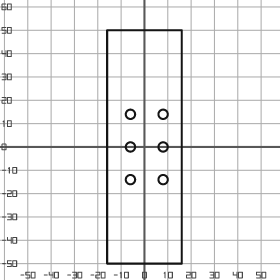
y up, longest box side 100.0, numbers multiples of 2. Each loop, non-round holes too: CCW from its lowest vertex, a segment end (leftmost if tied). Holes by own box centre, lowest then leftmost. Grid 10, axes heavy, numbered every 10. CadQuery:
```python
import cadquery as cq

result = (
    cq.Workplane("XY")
    .moveTo(-16.0, -50.0)
    .lineTo(16.0, -50.0)
    .lineTo(16.0, 50.0)
    .lineTo(-16.0, 50.0)
    .close()
    .moveTo(-6.0, -14.0)
    .circle(2.0)
    .moveTo(8.0, -14.0)
    .circle(2.0)
    .moveTo(-6.0, 0.0)
    .circle(2.0)
    .moveTo(8.0, 0.0)
    .circle(2.0)
    .moveTo(-6.0, 14.0)
    .circle(2.0)
    .moveTo(8.0, 14.0)
    .circle(2.0)
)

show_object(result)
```